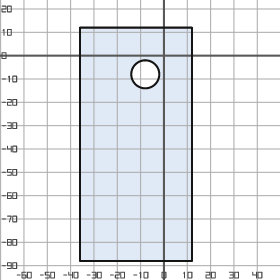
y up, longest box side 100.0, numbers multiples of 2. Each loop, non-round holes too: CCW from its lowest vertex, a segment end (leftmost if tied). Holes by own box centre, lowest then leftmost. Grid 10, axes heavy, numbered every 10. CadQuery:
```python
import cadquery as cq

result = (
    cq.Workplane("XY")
    .moveTo(-36.0, -88.0)
    .lineTo(12.0, -88.0)
    .lineTo(12.0, 12.0)
    .lineTo(-36.0, 12.0)
    .close()
    .moveTo(-8.0, -8.0)
    .circle(6.0)
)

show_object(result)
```